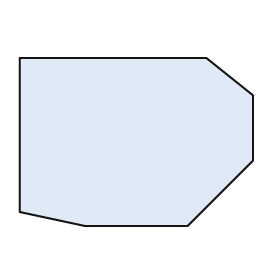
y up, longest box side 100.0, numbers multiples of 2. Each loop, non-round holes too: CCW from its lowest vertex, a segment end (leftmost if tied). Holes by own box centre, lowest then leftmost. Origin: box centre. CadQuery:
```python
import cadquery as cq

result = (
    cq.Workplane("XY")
    .moveTo(-22.0, -36.0)
    .lineTo(22.0, -36.0)
    .lineTo(50.0, -8.0)
    .lineTo(50.0, 20.0)
    .lineTo(30.0, 36.0)
    .lineTo(-50.0, 36.0)
    .lineTo(-50.0, -30.0)
    .close()
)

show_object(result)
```